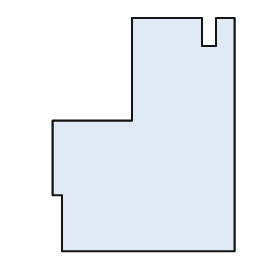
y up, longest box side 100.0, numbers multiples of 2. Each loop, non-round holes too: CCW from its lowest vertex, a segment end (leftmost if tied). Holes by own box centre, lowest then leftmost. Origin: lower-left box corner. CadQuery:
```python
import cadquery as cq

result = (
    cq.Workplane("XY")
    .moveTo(4.0, 0.0)
    .lineTo(78.0, 0.0)
    .lineTo(78.0, 100.0)
    .lineTo(70.0, 100.0)
    .lineTo(70.0, 88.0)
    .lineTo(64.0, 88.0)
    .lineTo(64.0, 100.0)
    .lineTo(34.0, 100.0)
    .lineTo(34.0, 56.0)
    .lineTo(0.0, 56.0)
    .lineTo(0.0, 24.0)
    .lineTo(4.0, 24.0)
    .close()
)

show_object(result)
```